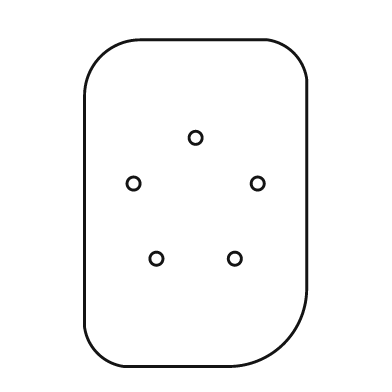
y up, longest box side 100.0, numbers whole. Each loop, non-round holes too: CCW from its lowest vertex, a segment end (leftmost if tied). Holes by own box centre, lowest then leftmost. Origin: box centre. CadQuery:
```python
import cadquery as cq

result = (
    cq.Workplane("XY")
    .moveTo(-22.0, -50.0)
    .lineTo(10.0, -50.0)
    .threePointArc((27.0, -43.0), (34.0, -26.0))
    .lineTo(34.0, 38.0)
    .threePointArc((30.0, 46.0), (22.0, 50.0))
    .lineTo(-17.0, 50.0)
    .threePointArc((-29.0, 45.0), (-34.0, 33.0))
    .lineTo(-34.0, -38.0)
    .threePointArc((-30.0, -46.0), (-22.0, -50.0))
    .close()
    .moveTo(-12.0, -17.0)
    .circle(2.0)
    .moveTo(12.0, -17.0)
    .circle(2.0)
    .moveTo(-19.0, 6.0)
    .circle(2.0)
    .moveTo(19.0, 6.0)
    .circle(2.0)
    .moveTo(0.0, 20.0)
    .circle(2.0)
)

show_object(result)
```